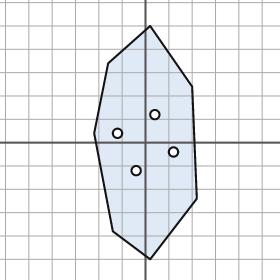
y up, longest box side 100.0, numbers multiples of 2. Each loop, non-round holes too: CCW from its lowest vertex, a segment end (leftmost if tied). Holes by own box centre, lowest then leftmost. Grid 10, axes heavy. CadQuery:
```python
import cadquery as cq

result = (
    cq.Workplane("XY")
    .moveTo(2.0, -50.0)
    .lineTo(22.0, -24.0)
    .lineTo(20.0, 24.0)
    .lineTo(2.0, 50.0)
    .lineTo(-16.0, 34.0)
    .lineTo(-22.0, 4.0)
    .lineTo(-14.0, -38.0)
    .close()
    .moveTo(-4.0, -12.0)
    .circle(2.0)
    .moveTo(12.0, -4.0)
    .circle(2.0)
    .moveTo(-12.0, 4.0)
    .circle(2.0)
    .moveTo(4.0, 12.0)
    .circle(2.0)
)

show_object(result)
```